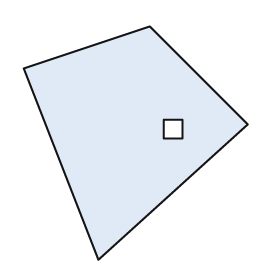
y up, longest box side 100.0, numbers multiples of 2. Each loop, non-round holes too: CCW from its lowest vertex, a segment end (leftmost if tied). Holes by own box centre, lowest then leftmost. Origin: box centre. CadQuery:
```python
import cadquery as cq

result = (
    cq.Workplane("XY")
    .moveTo(-16.0, -50.0)
    .lineTo(48.0, 8.0)
    .lineTo(6.0, 50.0)
    .lineTo(-48.0, 32.0)
    .close()
    .moveTo(12.0, 2.0)
    .lineTo(20.0, 2.0)
    .lineTo(20.0, 10.0)
    .lineTo(12.0, 10.0)
    .close()
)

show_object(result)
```